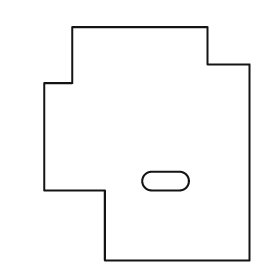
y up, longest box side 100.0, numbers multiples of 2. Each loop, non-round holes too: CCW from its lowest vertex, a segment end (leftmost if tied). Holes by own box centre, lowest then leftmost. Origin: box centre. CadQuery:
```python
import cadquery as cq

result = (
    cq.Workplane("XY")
    .moveTo(-18.0, -50.0)
    .lineTo(44.0, -50.0)
    .lineTo(44.0, 34.0)
    .lineTo(26.0, 34.0)
    .lineTo(26.0, 50.0)
    .lineTo(-32.0, 50.0)
    .lineTo(-32.0, 26.0)
    .lineTo(-44.0, 26.0)
    .lineTo(-44.0, -20.0)
    .lineTo(-18.0, -20.0)
    .close()
    .moveTo(2.0, -20.0)
    .lineTo(14.0, -20.0)
    .threePointArc((18.0, -16.0), (14.0, -12.0))
    .lineTo(2.0, -12.0)
    .threePointArc((-2.0, -16.0), (2.0, -20.0))
    .close()
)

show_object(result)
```